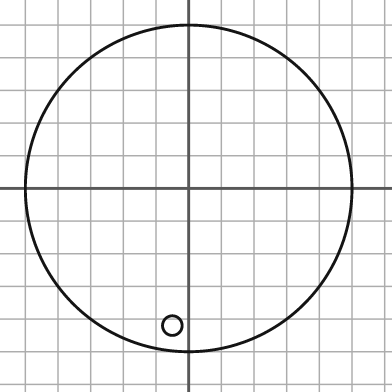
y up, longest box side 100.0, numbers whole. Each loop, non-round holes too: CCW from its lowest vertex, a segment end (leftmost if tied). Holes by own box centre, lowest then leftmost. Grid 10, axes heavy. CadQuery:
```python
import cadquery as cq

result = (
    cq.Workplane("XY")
    .moveTo(0.0, 0.0)
    .circle(50.0)
    .moveTo(-5.0, -42.0)
    .circle(3.0)
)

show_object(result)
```